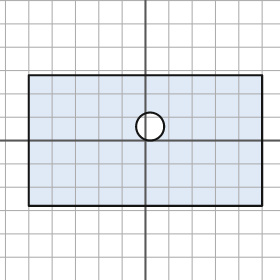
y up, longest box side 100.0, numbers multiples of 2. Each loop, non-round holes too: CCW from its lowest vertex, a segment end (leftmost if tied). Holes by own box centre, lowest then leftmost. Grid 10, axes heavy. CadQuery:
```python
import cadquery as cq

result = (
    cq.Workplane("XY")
    .moveTo(-50.0, -28.0)
    .lineTo(50.0, -28.0)
    .lineTo(50.0, 28.0)
    .lineTo(-50.0, 28.0)
    .close()
    .moveTo(2.0, 6.0)
    .circle(6.0)
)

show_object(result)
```